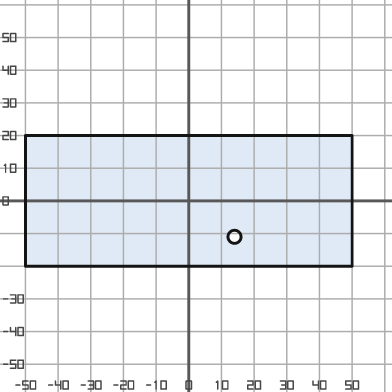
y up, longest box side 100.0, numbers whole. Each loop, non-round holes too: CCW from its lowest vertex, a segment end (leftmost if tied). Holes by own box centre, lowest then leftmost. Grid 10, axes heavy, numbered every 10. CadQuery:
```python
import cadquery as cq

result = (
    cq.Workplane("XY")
    .moveTo(-50.0, -20.0)
    .lineTo(50.0, -20.0)
    .lineTo(50.0, 20.0)
    .lineTo(-50.0, 20.0)
    .close()
    .moveTo(14.0, -11.0)
    .circle(2.0)
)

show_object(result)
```